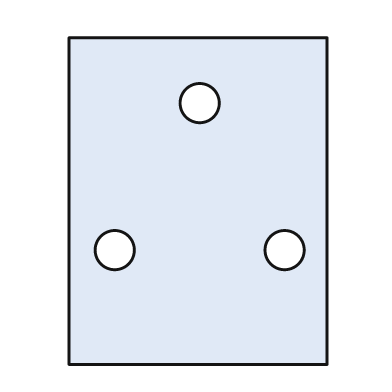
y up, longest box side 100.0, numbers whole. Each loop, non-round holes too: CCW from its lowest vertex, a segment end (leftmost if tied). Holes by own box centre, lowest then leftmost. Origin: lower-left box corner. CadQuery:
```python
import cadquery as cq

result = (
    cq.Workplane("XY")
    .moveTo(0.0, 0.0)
    .lineTo(79.0, 0.0)
    .lineTo(79.0, 100.0)
    .lineTo(0.0, 100.0)
    .close()
    .moveTo(14.0, 35.0)
    .circle(6.0)
    .moveTo(66.0, 35.0)
    .circle(6.0)
    .moveTo(40.0, 80.0)
    .circle(6.0)
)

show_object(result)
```